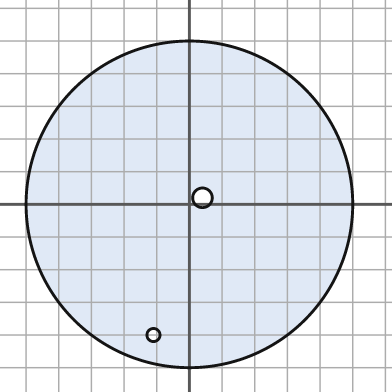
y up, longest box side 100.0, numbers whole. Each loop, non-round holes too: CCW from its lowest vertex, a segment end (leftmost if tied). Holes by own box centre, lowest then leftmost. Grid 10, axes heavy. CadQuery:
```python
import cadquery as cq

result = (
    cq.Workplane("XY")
    .moveTo(0.0, 0.0)
    .circle(50.0)
    .moveTo(-11.0, -40.0)
    .circle(2.0)
    .moveTo(4.0, 2.0)
    .circle(3.0)
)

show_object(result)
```